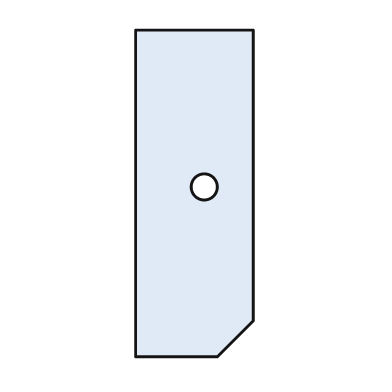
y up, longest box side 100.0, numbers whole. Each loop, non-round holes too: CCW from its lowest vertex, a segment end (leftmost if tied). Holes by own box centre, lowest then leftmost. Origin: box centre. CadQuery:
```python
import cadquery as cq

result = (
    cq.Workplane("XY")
    .moveTo(-18.0, -50.0)
    .lineTo(7.0, -50.0)
    .lineTo(18.0, -39.0)
    .lineTo(18.0, 50.0)
    .lineTo(-18.0, 50.0)
    .close()
    .moveTo(3.0, 2.0)
    .circle(4.0)
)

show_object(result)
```